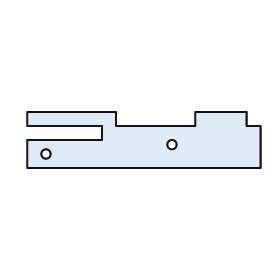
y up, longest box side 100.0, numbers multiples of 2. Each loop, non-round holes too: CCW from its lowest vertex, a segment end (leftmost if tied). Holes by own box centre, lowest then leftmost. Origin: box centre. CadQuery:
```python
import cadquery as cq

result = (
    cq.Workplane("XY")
    .moveTo(-50.0, -12.0)
    .lineTo(50.0, -12.0)
    .lineTo(50.0, 6.0)
    .lineTo(44.0, 6.0)
    .lineTo(44.0, 12.0)
    .lineTo(22.0, 12.0)
    .lineTo(22.0, 6.0)
    .lineTo(-12.0, 6.0)
    .lineTo(-12.0, 12.0)
    .lineTo(-50.0, 12.0)
    .lineTo(-50.0, 6.0)
    .lineTo(-18.0, 6.0)
    .lineTo(-18.0, 0.0)
    .lineTo(-50.0, 0.0)
    .close()
    .moveTo(-42.0, -6.0)
    .circle(2.0)
    .moveTo(12.0, -2.0)
    .circle(2.0)
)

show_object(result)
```